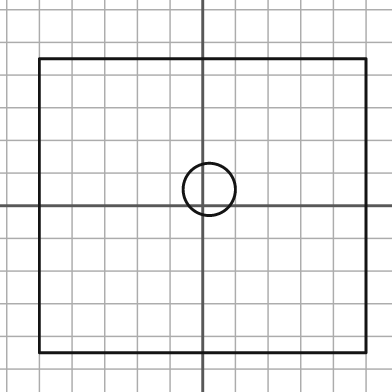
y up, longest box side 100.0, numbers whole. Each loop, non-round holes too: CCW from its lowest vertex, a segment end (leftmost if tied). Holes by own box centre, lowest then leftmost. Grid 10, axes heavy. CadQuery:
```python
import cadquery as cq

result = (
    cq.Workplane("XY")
    .moveTo(-50.0, -45.0)
    .lineTo(50.0, -45.0)
    .lineTo(50.0, 45.0)
    .lineTo(-50.0, 45.0)
    .close()
    .moveTo(2.0, 5.0)
    .circle(8.0)
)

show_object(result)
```